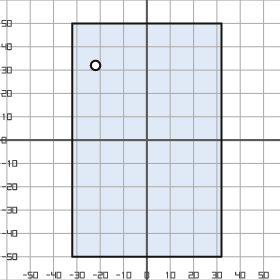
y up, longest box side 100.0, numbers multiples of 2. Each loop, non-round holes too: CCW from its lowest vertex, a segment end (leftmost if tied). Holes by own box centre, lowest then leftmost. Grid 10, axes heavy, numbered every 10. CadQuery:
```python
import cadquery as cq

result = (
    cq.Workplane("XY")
    .moveTo(-32.0, -50.0)
    .lineTo(32.0, -50.0)
    .lineTo(32.0, 50.0)
    .lineTo(-32.0, 50.0)
    .close()
    .moveTo(-22.0, 32.0)
    .circle(2.0)
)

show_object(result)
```